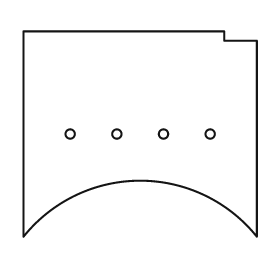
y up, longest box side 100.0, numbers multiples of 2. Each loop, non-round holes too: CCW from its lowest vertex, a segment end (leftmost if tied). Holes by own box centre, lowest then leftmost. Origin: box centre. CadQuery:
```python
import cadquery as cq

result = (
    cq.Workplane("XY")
    .moveTo(-50.0, -44.0)
    .threePointArc((0.0, -20.0), (50.0, -44.0))
    .lineTo(50.0, 40.0)
    .lineTo(36.0, 40.0)
    .lineTo(36.0, 44.0)
    .lineTo(-50.0, 44.0)
    .close()
    .moveTo(-30.0, 0.0)
    .circle(2.0)
    .moveTo(-10.0, 0.0)
    .circle(2.0)
    .moveTo(10.0, 0.0)
    .circle(2.0)
    .moveTo(30.0, 0.0)
    .circle(2.0)
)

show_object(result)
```